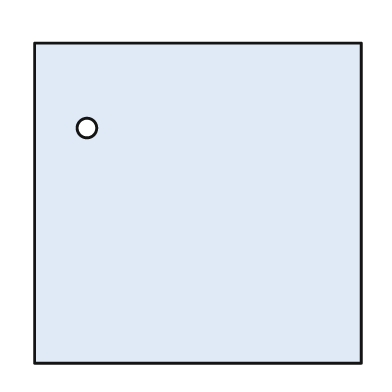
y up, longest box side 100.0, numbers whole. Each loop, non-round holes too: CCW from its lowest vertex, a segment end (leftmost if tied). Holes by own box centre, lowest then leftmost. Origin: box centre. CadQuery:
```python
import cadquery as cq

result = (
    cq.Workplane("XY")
    .moveTo(-50.0, -49.0)
    .lineTo(50.0, -49.0)
    .lineTo(50.0, 49.0)
    .lineTo(-50.0, 49.0)
    .close()
    .moveTo(-34.0, 23.0)
    .circle(3.0)
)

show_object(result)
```